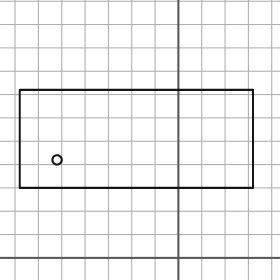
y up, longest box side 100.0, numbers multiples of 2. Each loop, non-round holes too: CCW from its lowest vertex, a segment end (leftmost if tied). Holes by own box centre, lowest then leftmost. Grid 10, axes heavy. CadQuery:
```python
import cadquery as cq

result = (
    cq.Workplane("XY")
    .moveTo(-68.0, 30.0)
    .lineTo(32.0, 30.0)
    .lineTo(32.0, 72.0)
    .lineTo(-68.0, 72.0)
    .close()
    .moveTo(-52.0, 42.0)
    .circle(2.0)
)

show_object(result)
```